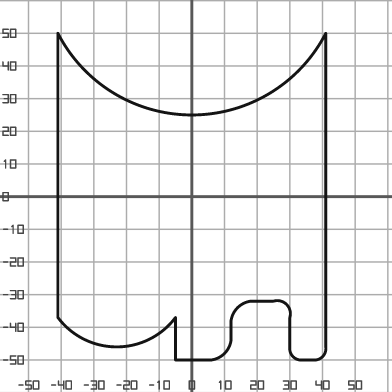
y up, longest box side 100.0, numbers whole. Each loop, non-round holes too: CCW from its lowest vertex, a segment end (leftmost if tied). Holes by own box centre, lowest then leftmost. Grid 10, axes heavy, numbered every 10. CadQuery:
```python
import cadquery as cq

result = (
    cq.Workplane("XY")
    .moveTo(-5.0, -50.0)
    .lineTo(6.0, -50.0)
    .threePointArc((10.0, -48.0), (12.0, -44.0))
    .lineTo(12.0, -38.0)
    .threePointArc((14.0, -34.0), (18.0, -32.0))
    .lineTo(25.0, -32.0)
    .threePointArc((29.0, -33.0), (30.0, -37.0))
    .lineTo(30.0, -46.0)
    .threePointArc((31.0, -49.0), (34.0, -50.0))
    .lineTo(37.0, -50.0)
    .threePointArc((40.0, -49.0), (41.0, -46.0))
    .lineTo(41.0, 50.0)
    .threePointArc((0.0, 25.0), (-41.0, 50.0))
    .lineTo(-41.0, -37.0)
    .threePointArc((-23.0, -46.0), (-5.0, -37.0))
    .close()
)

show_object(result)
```